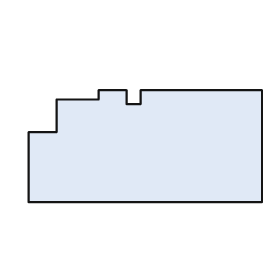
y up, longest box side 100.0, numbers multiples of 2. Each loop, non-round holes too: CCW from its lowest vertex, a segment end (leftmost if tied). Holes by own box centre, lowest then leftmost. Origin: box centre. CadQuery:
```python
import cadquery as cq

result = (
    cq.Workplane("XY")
    .moveTo(-50.0, -24.0)
    .lineTo(50.0, -24.0)
    .lineTo(50.0, 24.0)
    .lineTo(-2.0, 24.0)
    .lineTo(-2.0, 18.0)
    .lineTo(-8.0, 18.0)
    .lineTo(-8.0, 24.0)
    .lineTo(-20.0, 24.0)
    .lineTo(-20.0, 20.0)
    .lineTo(-38.0, 20.0)
    .lineTo(-38.0, 6.0)
    .lineTo(-50.0, 6.0)
    .close()
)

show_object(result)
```